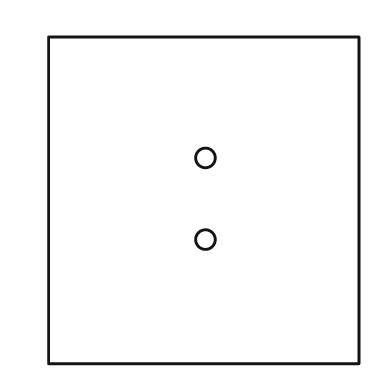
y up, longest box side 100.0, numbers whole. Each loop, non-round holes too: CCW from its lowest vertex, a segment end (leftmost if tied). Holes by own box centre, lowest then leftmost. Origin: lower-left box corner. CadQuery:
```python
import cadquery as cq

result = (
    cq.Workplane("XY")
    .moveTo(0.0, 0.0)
    .lineTo(95.0, 0.0)
    .lineTo(95.0, 100.0)
    .lineTo(0.0, 100.0)
    .close()
    .moveTo(48.0, 38.0)
    .circle(3.0)
    .moveTo(48.0, 63.0)
    .circle(3.0)
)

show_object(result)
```